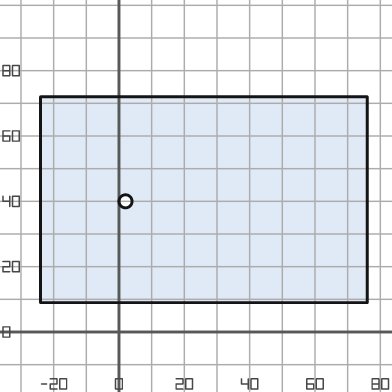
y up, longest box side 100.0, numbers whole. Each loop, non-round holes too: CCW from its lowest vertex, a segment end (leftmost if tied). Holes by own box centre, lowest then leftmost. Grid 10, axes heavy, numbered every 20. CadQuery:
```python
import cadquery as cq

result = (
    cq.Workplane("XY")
    .moveTo(-24.0, 9.0)
    .lineTo(76.0, 9.0)
    .lineTo(76.0, 72.0)
    .lineTo(-24.0, 72.0)
    .close()
    .moveTo(2.0, 40.0)
    .circle(2.0)
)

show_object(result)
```